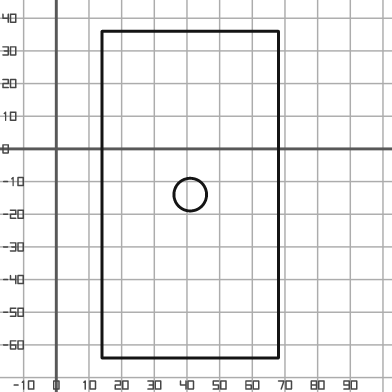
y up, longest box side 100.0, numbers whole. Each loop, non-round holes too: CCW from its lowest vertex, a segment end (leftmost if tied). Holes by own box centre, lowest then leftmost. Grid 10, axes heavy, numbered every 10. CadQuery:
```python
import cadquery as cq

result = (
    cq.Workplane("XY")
    .moveTo(14.0, -64.0)
    .lineTo(68.0, -64.0)
    .lineTo(68.0, 36.0)
    .lineTo(14.0, 36.0)
    .close()
    .moveTo(41.0, -14.0)
    .circle(5.0)
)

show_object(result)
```